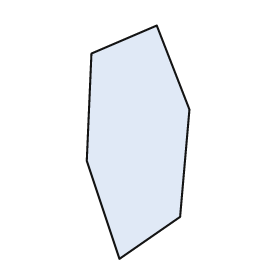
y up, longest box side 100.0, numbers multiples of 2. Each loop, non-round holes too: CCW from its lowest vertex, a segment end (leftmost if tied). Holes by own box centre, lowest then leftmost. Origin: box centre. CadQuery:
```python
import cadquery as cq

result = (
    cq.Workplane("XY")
    .moveTo(-8.0, -50.0)
    .lineTo(18.0, -32.0)
    .lineTo(22.0, 14.0)
    .lineTo(8.0, 50.0)
    .lineTo(-20.0, 38.0)
    .lineTo(-22.0, -8.0)
    .close()
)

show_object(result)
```